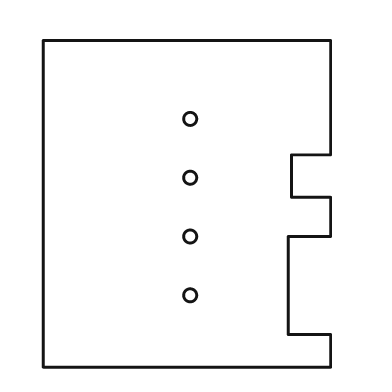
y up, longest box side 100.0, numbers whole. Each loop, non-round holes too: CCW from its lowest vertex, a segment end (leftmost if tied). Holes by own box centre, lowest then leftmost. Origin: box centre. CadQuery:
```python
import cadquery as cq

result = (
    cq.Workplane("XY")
    .moveTo(-44.0, -50.0)
    .lineTo(44.0, -50.0)
    .lineTo(44.0, -40.0)
    .lineTo(31.0, -40.0)
    .lineTo(31.0, -10.0)
    .lineTo(44.0, -10.0)
    .lineTo(44.0, 2.0)
    .lineTo(32.0, 2.0)
    .lineTo(32.0, 15.0)
    .lineTo(44.0, 15.0)
    .lineTo(44.0, 50.0)
    .lineTo(-44.0, 50.0)
    .close()
    .moveTo(1.0, -28.0)
    .circle(2.0)
    .moveTo(1.0, -10.0)
    .circle(2.0)
    .moveTo(1.0, 8.0)
    .circle(2.0)
    .moveTo(1.0, 26.0)
    .circle(2.0)
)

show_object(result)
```